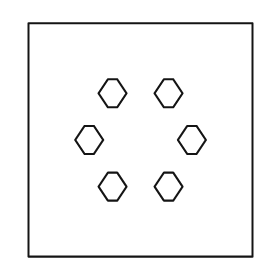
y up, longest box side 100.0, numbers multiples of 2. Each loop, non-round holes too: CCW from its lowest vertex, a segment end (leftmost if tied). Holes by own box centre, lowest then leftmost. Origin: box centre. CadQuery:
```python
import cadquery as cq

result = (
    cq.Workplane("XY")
    .moveTo(-48.0, -50.0)
    .lineTo(48.0, -50.0)
    .lineTo(48.0, 50.0)
    .lineTo(-48.0, 50.0)
    .close()
    .moveTo(-14.0, -26.0)
    .lineTo(-10.0, -26.0)
    .lineTo(-6.0, -20.0)
    .lineTo(-10.0, -14.0)
    .lineTo(-14.0, -14.0)
    .lineTo(-18.0, -20.0)
    .close()
    .moveTo(10.0, -26.0)
    .lineTo(14.0, -26.0)
    .lineTo(18.0, -20.0)
    .lineTo(14.0, -14.0)
    .lineTo(10.0, -14.0)
    .lineTo(6.0, -20.0)
    .close()
    .moveTo(-24.0, -6.0)
    .lineTo(-20.0, -6.0)
    .lineTo(-16.0, 0.0)
    .lineTo(-20.0, 6.0)
    .lineTo(-24.0, 6.0)
    .lineTo(-28.0, 0.0)
    .close()
    .moveTo(20.0, -6.0)
    .lineTo(24.0, -6.0)
    .lineTo(28.0, 0.0)
    .lineTo(24.0, 6.0)
    .lineTo(20.0, 6.0)
    .lineTo(16.0, 0.0)
    .close()
    .moveTo(-14.0, 14.0)
    .lineTo(-10.0, 14.0)
    .lineTo(-6.0, 20.0)
    .lineTo(-10.0, 26.0)
    .lineTo(-14.0, 26.0)
    .lineTo(-18.0, 20.0)
    .close()
    .moveTo(10.0, 14.0)
    .lineTo(14.0, 14.0)
    .lineTo(18.0, 20.0)
    .lineTo(14.0, 26.0)
    .lineTo(10.0, 26.0)
    .lineTo(6.0, 20.0)
    .close()
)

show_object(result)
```